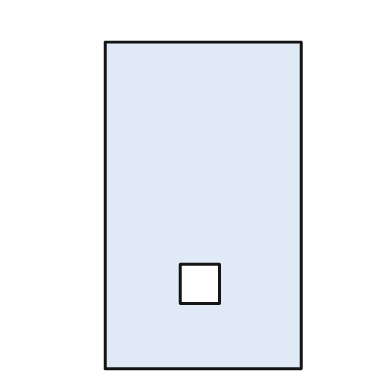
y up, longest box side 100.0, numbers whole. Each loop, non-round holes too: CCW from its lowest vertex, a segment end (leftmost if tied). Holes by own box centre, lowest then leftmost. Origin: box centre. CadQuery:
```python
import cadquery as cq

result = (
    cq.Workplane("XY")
    .moveTo(-30.0, -50.0)
    .lineTo(30.0, -50.0)
    .lineTo(30.0, 50.0)
    .lineTo(-30.0, 50.0)
    .close()
    .moveTo(-7.0, -30.0)
    .lineTo(5.0, -30.0)
    .lineTo(5.0, -18.0)
    .lineTo(-7.0, -18.0)
    .close()
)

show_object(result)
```